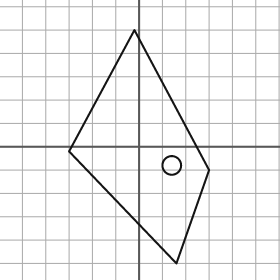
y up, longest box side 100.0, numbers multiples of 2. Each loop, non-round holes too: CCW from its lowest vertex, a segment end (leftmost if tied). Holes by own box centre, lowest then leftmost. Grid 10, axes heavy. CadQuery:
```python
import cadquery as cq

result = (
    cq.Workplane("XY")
    .moveTo(16.0, -50.0)
    .lineTo(30.0, -10.0)
    .lineTo(-2.0, 50.0)
    .lineTo(-30.0, -2.0)
    .close()
    .moveTo(14.0, -8.0)
    .circle(4.0)
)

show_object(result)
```